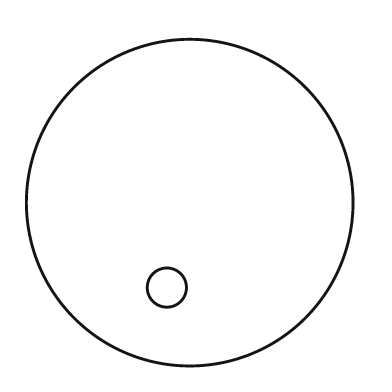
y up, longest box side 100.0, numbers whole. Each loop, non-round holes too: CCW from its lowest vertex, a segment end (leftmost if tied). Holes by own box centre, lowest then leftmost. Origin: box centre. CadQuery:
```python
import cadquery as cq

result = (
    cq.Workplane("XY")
    .moveTo(0.0, 0.0)
    .circle(50.0)
    .moveTo(-7.0, -26.0)
    .circle(6.0)
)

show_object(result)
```